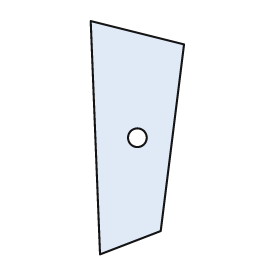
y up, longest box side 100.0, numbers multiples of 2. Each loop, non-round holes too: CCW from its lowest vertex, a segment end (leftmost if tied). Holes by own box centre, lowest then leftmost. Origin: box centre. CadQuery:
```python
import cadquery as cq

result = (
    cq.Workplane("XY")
    .moveTo(-16.0, -50.0)
    .lineTo(10.0, -40.0)
    .lineTo(20.0, 40.0)
    .lineTo(-20.0, 50.0)
    .close()
    .moveTo(0.0, 0.0)
    .circle(4.0)
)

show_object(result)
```